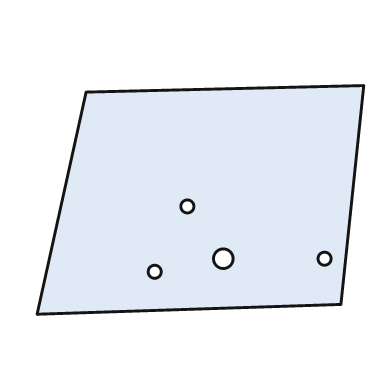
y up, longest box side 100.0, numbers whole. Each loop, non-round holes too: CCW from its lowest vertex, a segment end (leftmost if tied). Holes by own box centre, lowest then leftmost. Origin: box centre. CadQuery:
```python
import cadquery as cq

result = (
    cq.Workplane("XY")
    .moveTo(-50.0, -35.0)
    .lineTo(43.0, -32.0)
    .lineTo(50.0, 35.0)
    .lineTo(-35.0, 33.0)
    .close()
    .moveTo(-14.0, -22.0)
    .circle(2.0)
    .moveTo(7.0, -18.0)
    .circle(3.0)
    .moveTo(38.0, -18.0)
    .circle(2.0)
    .moveTo(-4.0, -2.0)
    .circle(2.0)
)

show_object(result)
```